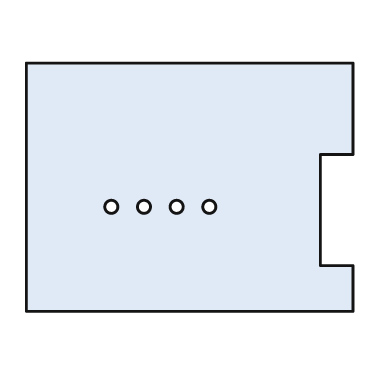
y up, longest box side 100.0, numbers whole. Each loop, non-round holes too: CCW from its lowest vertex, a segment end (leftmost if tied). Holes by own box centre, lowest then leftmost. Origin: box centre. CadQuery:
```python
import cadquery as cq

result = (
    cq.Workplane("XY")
    .moveTo(-50.0, -38.0)
    .lineTo(50.0, -38.0)
    .lineTo(50.0, -24.0)
    .lineTo(40.0, -24.0)
    .lineTo(40.0, 10.0)
    .lineTo(50.0, 10.0)
    .lineTo(50.0, 38.0)
    .lineTo(-50.0, 38.0)
    .close()
    .moveTo(-24.0, -6.0)
    .circle(2.0)
    .moveTo(-14.0, -6.0)
    .circle(2.0)
    .moveTo(-4.0, -6.0)
    .circle(2.0)
    .moveTo(6.0, -6.0)
    .circle(2.0)
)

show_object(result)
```